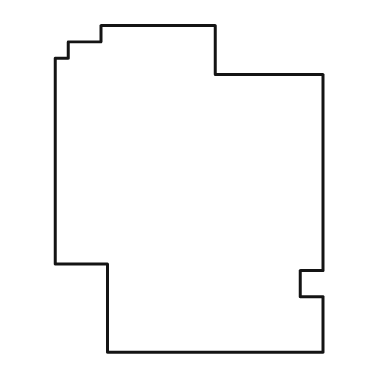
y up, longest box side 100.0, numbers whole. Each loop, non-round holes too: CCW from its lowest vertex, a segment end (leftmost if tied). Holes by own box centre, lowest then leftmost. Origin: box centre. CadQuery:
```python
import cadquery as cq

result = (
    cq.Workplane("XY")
    .moveTo(-25.0, -50.0)
    .lineTo(41.0, -50.0)
    .lineTo(41.0, -33.0)
    .lineTo(34.0, -33.0)
    .lineTo(34.0, -25.0)
    .lineTo(41.0, -25.0)
    .lineTo(41.0, 35.0)
    .lineTo(8.0, 35.0)
    .lineTo(8.0, 50.0)
    .lineTo(-27.0, 50.0)
    .lineTo(-27.0, 45.0)
    .lineTo(-37.0, 45.0)
    .lineTo(-37.0, 40.0)
    .lineTo(-41.0, 40.0)
    .lineTo(-41.0, -23.0)
    .lineTo(-25.0, -23.0)
    .close()
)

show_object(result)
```